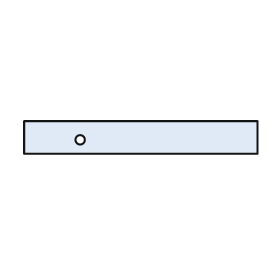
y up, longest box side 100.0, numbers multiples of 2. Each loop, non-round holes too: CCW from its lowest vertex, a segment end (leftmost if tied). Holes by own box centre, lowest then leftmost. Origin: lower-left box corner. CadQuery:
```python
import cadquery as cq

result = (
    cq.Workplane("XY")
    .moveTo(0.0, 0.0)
    .lineTo(100.0, 0.0)
    .lineTo(100.0, 14.0)
    .lineTo(0.0, 14.0)
    .close()
    .moveTo(24.0, 6.0)
    .circle(2.0)
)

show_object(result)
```